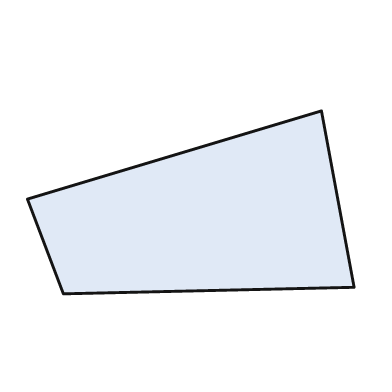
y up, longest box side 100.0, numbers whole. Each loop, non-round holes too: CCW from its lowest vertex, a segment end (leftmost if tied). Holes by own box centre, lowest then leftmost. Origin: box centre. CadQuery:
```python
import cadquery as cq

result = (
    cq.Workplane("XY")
    .moveTo(-39.0, -28.0)
    .lineTo(50.0, -26.0)
    .lineTo(40.0, 28.0)
    .lineTo(-50.0, 1.0)
    .close()
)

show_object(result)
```